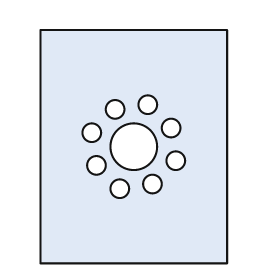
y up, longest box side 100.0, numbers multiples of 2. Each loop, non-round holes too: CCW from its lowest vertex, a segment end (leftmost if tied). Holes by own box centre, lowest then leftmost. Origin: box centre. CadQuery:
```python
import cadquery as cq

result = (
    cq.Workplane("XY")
    .moveTo(-40.0, -50.0)
    .lineTo(40.0, -50.0)
    .lineTo(40.0, 50.0)
    .lineTo(-40.0, 50.0)
    .close()
    .moveTo(-6.0, -18.0)
    .circle(4.0)
    .moveTo(8.0, -16.0)
    .circle(4.0)
    .moveTo(-16.0, -8.0)
    .circle(4.0)
    .moveTo(18.0, -6.0)
    .circle(4.0)
    .moveTo(0.0, 0.0)
    .circle(10.0)
    .moveTo(-18.0, 6.0)
    .circle(4.0)
    .moveTo(16.0, 8.0)
    .circle(4.0)
    .moveTo(-8.0, 16.0)
    .circle(4.0)
    .moveTo(6.0, 18.0)
    .circle(4.0)
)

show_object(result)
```